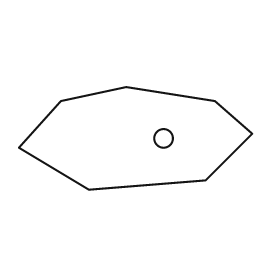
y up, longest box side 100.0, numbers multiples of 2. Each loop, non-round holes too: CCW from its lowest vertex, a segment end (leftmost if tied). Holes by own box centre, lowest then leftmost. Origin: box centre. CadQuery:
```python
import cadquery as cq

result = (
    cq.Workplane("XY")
    .moveTo(-20.0, -22.0)
    .lineTo(30.0, -18.0)
    .lineTo(50.0, 2.0)
    .lineTo(34.0, 16.0)
    .lineTo(-4.0, 22.0)
    .lineTo(-32.0, 16.0)
    .lineTo(-50.0, -4.0)
    .close()
    .moveTo(12.0, 0.0)
    .circle(4.0)
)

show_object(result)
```